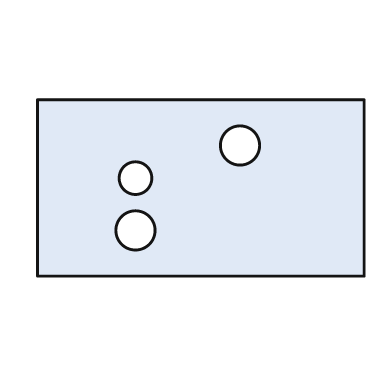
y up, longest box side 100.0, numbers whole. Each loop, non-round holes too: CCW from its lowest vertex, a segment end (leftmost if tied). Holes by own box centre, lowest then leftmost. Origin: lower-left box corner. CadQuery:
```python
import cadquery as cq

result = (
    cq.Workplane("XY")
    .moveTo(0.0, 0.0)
    .lineTo(100.0, 0.0)
    .lineTo(100.0, 54.0)
    .lineTo(0.0, 54.0)
    .close()
    .moveTo(30.0, 14.0)
    .circle(6.0)
    .moveTo(30.0, 30.0)
    .circle(5.0)
    .moveTo(62.0, 40.0)
    .circle(6.0)
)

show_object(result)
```